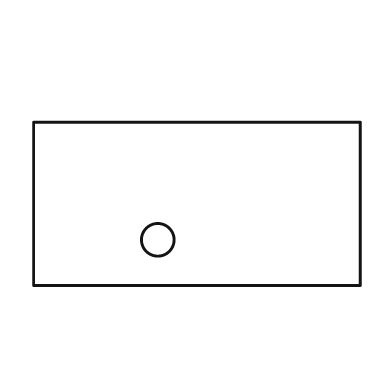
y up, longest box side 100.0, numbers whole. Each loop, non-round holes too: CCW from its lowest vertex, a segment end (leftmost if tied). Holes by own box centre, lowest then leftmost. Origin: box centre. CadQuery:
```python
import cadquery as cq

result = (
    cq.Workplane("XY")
    .moveTo(-50.0, -25.0)
    .lineTo(50.0, -25.0)
    .lineTo(50.0, 25.0)
    .lineTo(-50.0, 25.0)
    .close()
    .moveTo(-12.0, -11.0)
    .circle(5.0)
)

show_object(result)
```